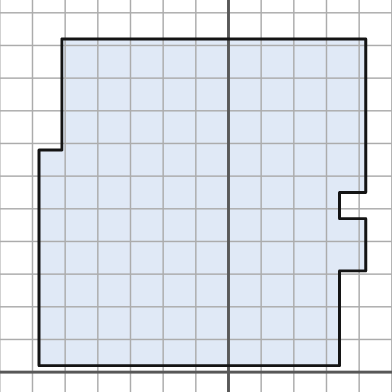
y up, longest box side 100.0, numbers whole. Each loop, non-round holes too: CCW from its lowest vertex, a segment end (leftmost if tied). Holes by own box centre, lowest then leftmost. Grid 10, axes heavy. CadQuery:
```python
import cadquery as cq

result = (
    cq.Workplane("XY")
    .moveTo(-58.0, 2.0)
    .lineTo(34.0, 2.0)
    .lineTo(34.0, 31.0)
    .lineTo(42.0, 31.0)
    .lineTo(42.0, 47.0)
    .lineTo(34.0, 47.0)
    .lineTo(34.0, 55.0)
    .lineTo(42.0, 55.0)
    .lineTo(42.0, 102.0)
    .lineTo(-51.0, 102.0)
    .lineTo(-51.0, 68.0)
    .lineTo(-58.0, 68.0)
    .close()
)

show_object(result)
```